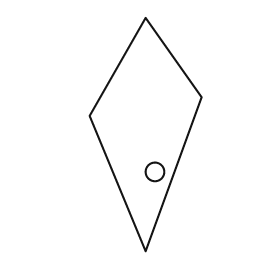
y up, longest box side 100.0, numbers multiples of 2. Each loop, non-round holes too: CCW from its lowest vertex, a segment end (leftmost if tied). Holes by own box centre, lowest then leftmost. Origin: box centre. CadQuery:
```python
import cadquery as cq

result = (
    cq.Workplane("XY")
    .moveTo(0.0, -50.0)
    .lineTo(24.0, 16.0)
    .lineTo(0.0, 50.0)
    .lineTo(-24.0, 8.0)
    .close()
    .moveTo(4.0, -16.0)
    .circle(4.0)
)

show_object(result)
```